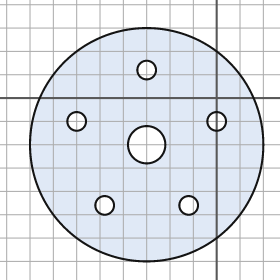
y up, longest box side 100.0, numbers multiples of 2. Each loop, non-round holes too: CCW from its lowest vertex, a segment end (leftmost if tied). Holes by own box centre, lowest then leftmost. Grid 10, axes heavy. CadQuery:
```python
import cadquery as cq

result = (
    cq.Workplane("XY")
    .moveTo(-30.0, -20.0)
    .circle(50.0)
    .moveTo(-48.0, -46.0)
    .circle(4.0)
    .moveTo(-12.0, -46.0)
    .circle(4.0)
    .moveTo(-30.0, -20.0)
    .circle(8.0)
    .moveTo(-60.0, -10.0)
    .circle(4.0)
    .moveTo(0.0, -10.0)
    .circle(4.0)
    .moveTo(-30.0, 12.0)
    .circle(4.0)
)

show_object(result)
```